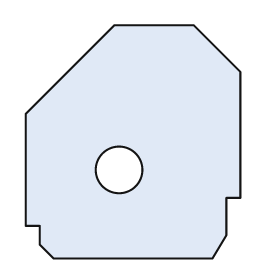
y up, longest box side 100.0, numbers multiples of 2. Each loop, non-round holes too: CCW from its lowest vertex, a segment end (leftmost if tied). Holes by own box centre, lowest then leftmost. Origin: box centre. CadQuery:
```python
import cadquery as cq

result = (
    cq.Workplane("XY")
    .moveTo(-34.0, -50.0)
    .lineTo(34.0, -50.0)
    .lineTo(40.0, -40.0)
    .lineTo(40.0, -24.0)
    .lineTo(46.0, -24.0)
    .lineTo(46.0, 30.0)
    .lineTo(26.0, 50.0)
    .lineTo(-8.0, 50.0)
    .lineTo(-46.0, 12.0)
    .lineTo(-46.0, -36.0)
    .lineTo(-40.0, -36.0)
    .lineTo(-40.0, -44.0)
    .close()
    .moveTo(-6.0, -12.0)
    .circle(10.0)
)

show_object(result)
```